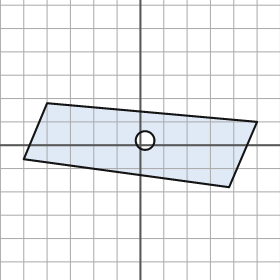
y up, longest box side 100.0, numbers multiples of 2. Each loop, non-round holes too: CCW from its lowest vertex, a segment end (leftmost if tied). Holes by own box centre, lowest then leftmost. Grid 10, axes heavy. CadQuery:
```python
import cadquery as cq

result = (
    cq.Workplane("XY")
    .moveTo(38.0, -18.0)
    .lineTo(50.0, 10.0)
    .lineTo(-40.0, 18.0)
    .lineTo(-50.0, -6.0)
    .close()
    .moveTo(2.0, 2.0)
    .circle(4.0)
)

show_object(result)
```